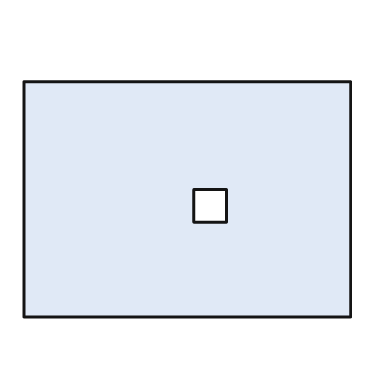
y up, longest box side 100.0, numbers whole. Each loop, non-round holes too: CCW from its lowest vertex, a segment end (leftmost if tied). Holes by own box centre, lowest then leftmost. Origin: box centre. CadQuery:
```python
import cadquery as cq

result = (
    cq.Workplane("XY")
    .moveTo(-50.0, -36.0)
    .lineTo(50.0, -36.0)
    .lineTo(50.0, 36.0)
    .lineTo(-50.0, 36.0)
    .close()
    .moveTo(2.0, -7.0)
    .lineTo(12.0, -7.0)
    .lineTo(12.0, 3.0)
    .lineTo(2.0, 3.0)
    .close()
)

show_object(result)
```